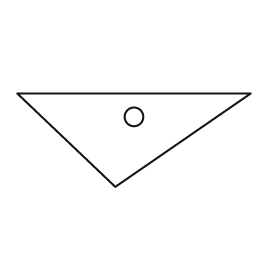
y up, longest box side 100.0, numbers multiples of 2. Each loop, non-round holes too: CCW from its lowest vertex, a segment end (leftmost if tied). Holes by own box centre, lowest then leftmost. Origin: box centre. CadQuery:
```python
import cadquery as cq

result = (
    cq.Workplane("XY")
    .moveTo(-8.0, -20.0)
    .lineTo(50.0, 20.0)
    .lineTo(-50.0, 20.0)
    .close()
    .moveTo(0.0, 10.0)
    .circle(4.0)
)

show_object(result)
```